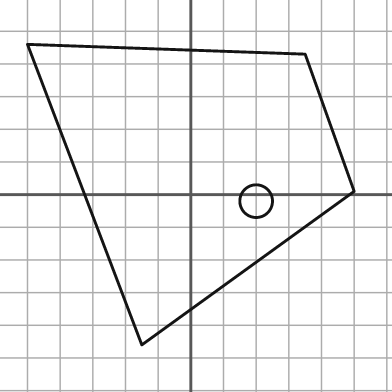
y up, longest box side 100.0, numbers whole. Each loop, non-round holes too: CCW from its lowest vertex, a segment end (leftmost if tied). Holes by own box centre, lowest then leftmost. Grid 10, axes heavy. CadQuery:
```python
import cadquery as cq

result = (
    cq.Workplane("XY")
    .moveTo(-15.0, -46.0)
    .lineTo(50.0, 1.0)
    .lineTo(35.0, 43.0)
    .lineTo(-50.0, 46.0)
    .close()
    .moveTo(20.0, -2.0)
    .circle(5.0)
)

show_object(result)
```